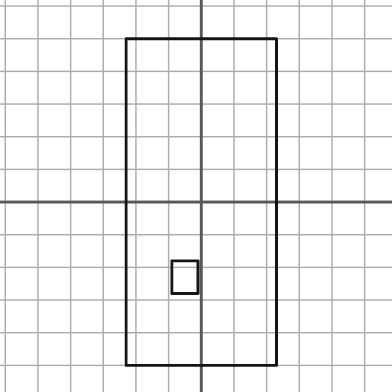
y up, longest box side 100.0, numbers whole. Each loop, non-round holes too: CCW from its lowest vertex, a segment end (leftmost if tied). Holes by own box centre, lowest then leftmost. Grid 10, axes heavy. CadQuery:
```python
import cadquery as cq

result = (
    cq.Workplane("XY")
    .moveTo(-23.0, -50.0)
    .lineTo(23.0, -50.0)
    .lineTo(23.0, 50.0)
    .lineTo(-23.0, 50.0)
    .close()
    .moveTo(-9.0, -28.0)
    .lineTo(-1.0, -28.0)
    .lineTo(-1.0, -18.0)
    .lineTo(-9.0, -18.0)
    .close()
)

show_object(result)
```